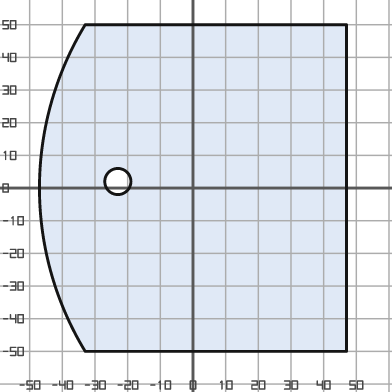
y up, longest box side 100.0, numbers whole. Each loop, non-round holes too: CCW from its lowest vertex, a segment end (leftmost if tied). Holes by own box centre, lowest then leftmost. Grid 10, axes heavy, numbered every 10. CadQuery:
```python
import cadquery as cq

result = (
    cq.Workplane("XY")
    .moveTo(-33.0, -50.0)
    .lineTo(47.0, -50.0)
    .lineTo(47.0, 50.0)
    .lineTo(-33.0, 50.0)
    .threePointArc((-47.0, 0.0), (-33.0, -50.0))
    .close()
    .moveTo(-23.0, 2.0)
    .circle(4.0)
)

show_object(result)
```